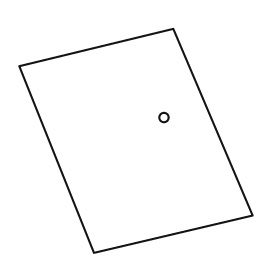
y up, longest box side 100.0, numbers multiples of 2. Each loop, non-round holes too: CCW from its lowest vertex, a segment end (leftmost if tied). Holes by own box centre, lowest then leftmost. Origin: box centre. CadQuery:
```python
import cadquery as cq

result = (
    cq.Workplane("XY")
    .moveTo(-18.0, -48.0)
    .lineTo(50.0, -32.0)
    .lineTo(16.0, 48.0)
    .lineTo(-50.0, 32.0)
    .close()
    .moveTo(12.0, 10.0)
    .circle(2.0)
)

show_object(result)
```